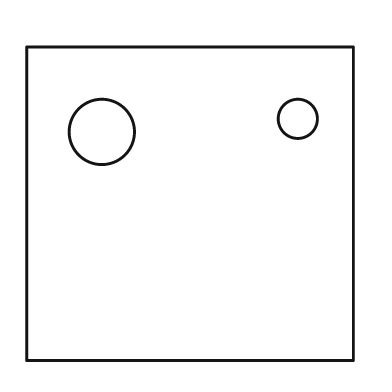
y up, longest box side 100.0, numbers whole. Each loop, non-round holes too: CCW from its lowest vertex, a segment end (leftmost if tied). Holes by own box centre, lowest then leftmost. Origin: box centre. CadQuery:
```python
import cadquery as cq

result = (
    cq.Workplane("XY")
    .moveTo(-50.0, -48.0)
    .lineTo(50.0, -48.0)
    .lineTo(50.0, 48.0)
    .lineTo(-50.0, 48.0)
    .close()
    .moveTo(-27.0, 22.0)
    .circle(10.0)
    .moveTo(33.0, 26.0)
    .circle(6.0)
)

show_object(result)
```